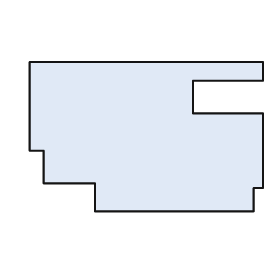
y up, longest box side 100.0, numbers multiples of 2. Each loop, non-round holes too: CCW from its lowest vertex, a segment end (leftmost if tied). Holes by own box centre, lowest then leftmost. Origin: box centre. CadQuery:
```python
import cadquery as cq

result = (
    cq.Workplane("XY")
    .moveTo(-22.0, -32.0)
    .lineTo(46.0, -32.0)
    .lineTo(46.0, -22.0)
    .lineTo(50.0, -22.0)
    .lineTo(50.0, 10.0)
    .lineTo(20.0, 10.0)
    .lineTo(20.0, 24.0)
    .lineTo(50.0, 24.0)
    .lineTo(50.0, 32.0)
    .lineTo(-50.0, 32.0)
    .lineTo(-50.0, -6.0)
    .lineTo(-44.0, -6.0)
    .lineTo(-44.0, -20.0)
    .lineTo(-22.0, -20.0)
    .close()
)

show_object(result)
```